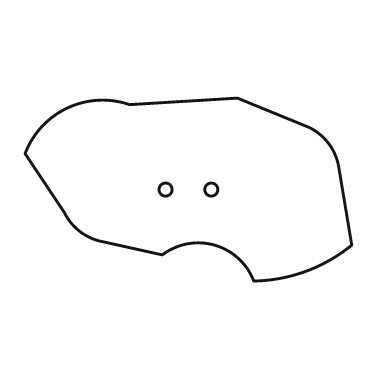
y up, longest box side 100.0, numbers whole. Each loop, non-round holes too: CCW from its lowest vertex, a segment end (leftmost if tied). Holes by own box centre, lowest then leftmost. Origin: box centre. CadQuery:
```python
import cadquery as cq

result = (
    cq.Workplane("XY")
    .moveTo(20.0, -28.0)
    .threePointArc((36.0, -25.0), (50.0, -17.0))
    .lineTo(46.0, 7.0)
    .threePointArc((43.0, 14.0), (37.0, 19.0))
    .lineTo(15.0, 28.0)
    .lineTo(-18.0, 26.0)
    .threePointArc((-37.0, 25.0), (-50.0, 11.0))
    .lineTo(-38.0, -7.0)
    .threePointArc((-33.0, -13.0), (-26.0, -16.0))
    .lineTo(-8.0, -20.0)
    .threePointArc((8.0, -17.0), (20.0, -28.0))
    .close()
    .moveTo(-7.0, 0.0)
    .circle(2.0)
    .moveTo(7.0, 0.0)
    .circle(2.0)
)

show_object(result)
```